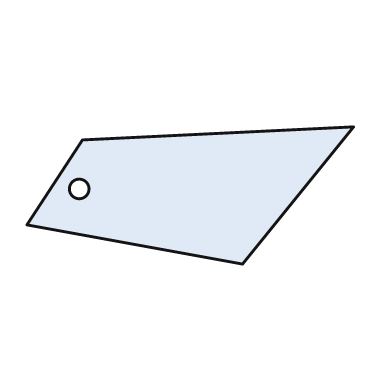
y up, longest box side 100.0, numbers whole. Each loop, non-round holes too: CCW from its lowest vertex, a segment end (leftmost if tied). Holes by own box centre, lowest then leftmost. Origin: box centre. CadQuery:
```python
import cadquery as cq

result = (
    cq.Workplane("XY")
    .moveTo(16.0, -21.0)
    .lineTo(50.0, 21.0)
    .lineTo(-33.0, 17.0)
    .lineTo(-50.0, -9.0)
    .close()
    .moveTo(-34.0, 2.0)
    .circle(3.0)
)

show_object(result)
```